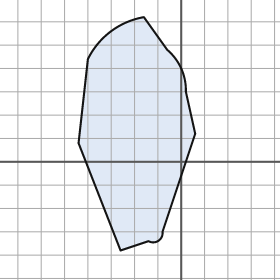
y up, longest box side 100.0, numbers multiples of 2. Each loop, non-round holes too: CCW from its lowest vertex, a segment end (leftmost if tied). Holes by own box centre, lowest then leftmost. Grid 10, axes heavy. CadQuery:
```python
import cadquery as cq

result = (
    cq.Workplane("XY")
    .moveTo(-26.0, -38.0)
    .lineTo(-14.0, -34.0)
    .threePointArc((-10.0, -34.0), (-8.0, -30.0))
    .lineTo(6.0, 12.0)
    .lineTo(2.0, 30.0)
    .threePointArc((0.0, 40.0), (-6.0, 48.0))
    .lineTo(-16.0, 62.0)
    .threePointArc((-30.0, 56.0), (-40.0, 44.0))
    .lineTo(-44.0, 8.0)
    .close()
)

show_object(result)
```